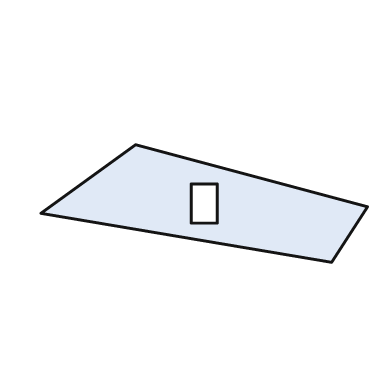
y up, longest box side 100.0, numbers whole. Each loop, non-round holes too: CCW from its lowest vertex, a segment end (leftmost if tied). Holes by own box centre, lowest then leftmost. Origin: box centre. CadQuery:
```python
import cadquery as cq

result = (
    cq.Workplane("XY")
    .moveTo(39.0, -18.0)
    .lineTo(50.0, -1.0)
    .lineTo(-21.0, 18.0)
    .lineTo(-50.0, -3.0)
    .close()
    .moveTo(-4.0, -6.0)
    .lineTo(4.0, -6.0)
    .lineTo(4.0, 6.0)
    .lineTo(-4.0, 6.0)
    .close()
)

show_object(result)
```